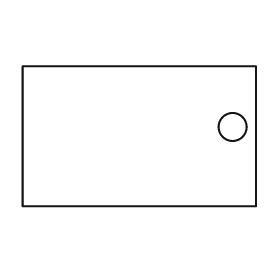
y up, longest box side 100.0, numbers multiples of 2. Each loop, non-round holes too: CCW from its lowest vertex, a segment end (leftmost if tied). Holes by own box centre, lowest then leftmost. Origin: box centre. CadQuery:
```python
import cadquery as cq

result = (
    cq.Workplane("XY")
    .moveTo(-50.0, -30.0)
    .lineTo(50.0, -30.0)
    .lineTo(50.0, 30.0)
    .lineTo(-50.0, 30.0)
    .close()
    .moveTo(40.0, 4.0)
    .circle(6.0)
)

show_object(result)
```